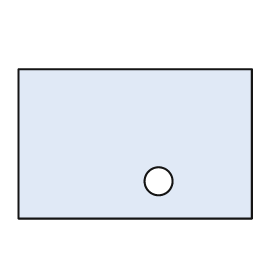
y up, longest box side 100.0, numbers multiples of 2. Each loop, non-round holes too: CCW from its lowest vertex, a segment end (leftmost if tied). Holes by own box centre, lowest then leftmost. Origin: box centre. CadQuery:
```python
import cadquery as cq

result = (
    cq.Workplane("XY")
    .moveTo(-50.0, -32.0)
    .lineTo(50.0, -32.0)
    .lineTo(50.0, 32.0)
    .lineTo(-50.0, 32.0)
    .close()
    .moveTo(10.0, -16.0)
    .circle(6.0)
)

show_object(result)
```